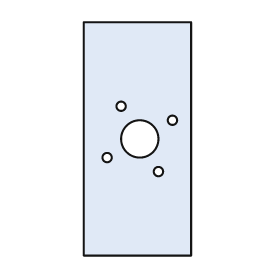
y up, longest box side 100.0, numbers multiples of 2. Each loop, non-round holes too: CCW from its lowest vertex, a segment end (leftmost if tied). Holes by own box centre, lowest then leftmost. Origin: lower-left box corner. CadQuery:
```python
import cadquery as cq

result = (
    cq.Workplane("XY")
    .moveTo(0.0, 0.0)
    .lineTo(46.0, 0.0)
    .lineTo(46.0, 100.0)
    .lineTo(0.0, 100.0)
    .close()
    .moveTo(32.0, 36.0)
    .circle(2.0)
    .moveTo(10.0, 42.0)
    .circle(2.0)
    .moveTo(24.0, 50.0)
    .circle(8.0)
    .moveTo(38.0, 58.0)
    .circle(2.0)
    .moveTo(16.0, 64.0)
    .circle(2.0)
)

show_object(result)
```